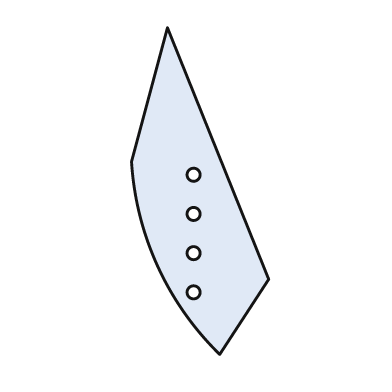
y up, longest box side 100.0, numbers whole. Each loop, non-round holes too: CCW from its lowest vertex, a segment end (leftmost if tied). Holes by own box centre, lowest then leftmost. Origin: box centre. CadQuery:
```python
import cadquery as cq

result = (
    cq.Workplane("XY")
    .moveTo(6.0, -50.0)
    .lineTo(21.0, -27.0)
    .lineTo(-10.0, 50.0)
    .lineTo(-21.0, 9.0)
    .threePointArc((-13.0, -23.0), (6.0, -50.0))
    .close()
    .moveTo(-2.0, -31.0)
    .circle(2.0)
    .moveTo(-2.0, -19.0)
    .circle(2.0)
    .moveTo(-2.0, -7.0)
    .circle(2.0)
    .moveTo(-2.0, 5.0)
    .circle(2.0)
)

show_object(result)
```